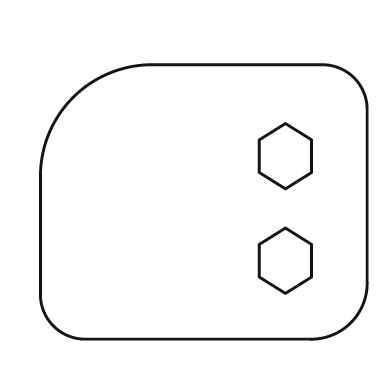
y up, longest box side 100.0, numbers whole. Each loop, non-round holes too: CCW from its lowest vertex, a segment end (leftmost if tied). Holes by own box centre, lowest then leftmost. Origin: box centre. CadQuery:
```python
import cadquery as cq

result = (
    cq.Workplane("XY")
    .moveTo(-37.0, -42.0)
    .lineTo(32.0, -42.0)
    .threePointArc((45.0, -37.0), (50.0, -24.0))
    .lineTo(50.0, 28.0)
    .threePointArc((46.0, 38.0), (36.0, 42.0))
    .lineTo(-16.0, 42.0)
    .threePointArc((-40.0, 32.0), (-50.0, 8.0))
    .lineTo(-50.0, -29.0)
    .threePointArc((-46.0, -38.0), (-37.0, -42.0))
    .close()
    .moveTo(25.0, -28.0)
    .lineTo(33.0, -23.0)
    .lineTo(33.0, -13.0)
    .lineTo(25.0, -8.0)
    .lineTo(17.0, -13.0)
    .lineTo(17.0, -23.0)
    .close()
    .moveTo(25.0, 4.0)
    .lineTo(33.0, 9.0)
    .lineTo(33.0, 19.0)
    .lineTo(25.0, 24.0)
    .lineTo(17.0, 19.0)
    .lineTo(17.0, 9.0)
    .close()
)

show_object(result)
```